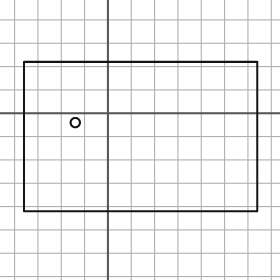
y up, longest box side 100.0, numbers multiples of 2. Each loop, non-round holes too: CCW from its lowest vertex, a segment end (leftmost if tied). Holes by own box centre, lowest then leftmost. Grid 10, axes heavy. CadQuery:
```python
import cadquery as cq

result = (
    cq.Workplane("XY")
    .moveTo(-36.0, -42.0)
    .lineTo(64.0, -42.0)
    .lineTo(64.0, 22.0)
    .lineTo(-36.0, 22.0)
    .close()
    .moveTo(-14.0, -4.0)
    .circle(2.0)
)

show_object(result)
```